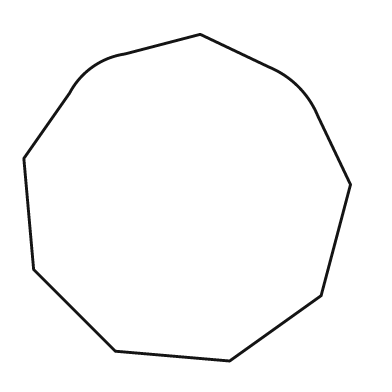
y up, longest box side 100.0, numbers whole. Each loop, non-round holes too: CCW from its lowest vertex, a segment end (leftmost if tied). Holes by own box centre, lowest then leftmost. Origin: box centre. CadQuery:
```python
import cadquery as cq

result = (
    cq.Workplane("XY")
    .moveTo(13.0, -50.0)
    .lineTo(41.0, -30.0)
    .lineTo(50.0, 4.0)
    .lineTo(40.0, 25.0)
    .threePointArc((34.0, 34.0), (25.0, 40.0))
    .lineTo(4.0, 50.0)
    .lineTo(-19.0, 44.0)
    .threePointArc((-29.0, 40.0), (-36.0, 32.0))
    .lineTo(-50.0, 12.0)
    .lineTo(-47.0, -22.0)
    .lineTo(-22.0, -47.0)
    .close()
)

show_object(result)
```